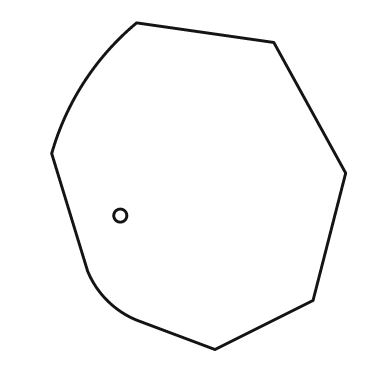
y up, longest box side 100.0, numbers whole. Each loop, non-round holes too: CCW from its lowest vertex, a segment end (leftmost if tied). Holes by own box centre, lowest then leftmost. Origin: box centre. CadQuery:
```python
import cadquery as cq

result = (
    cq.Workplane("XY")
    .moveTo(5.0, -50.0)
    .lineTo(35.0, -35.0)
    .lineTo(45.0, 4.0)
    .lineTo(23.0, 44.0)
    .lineTo(-19.0, 50.0)
    .threePointArc((-35.0, 32.0), (-45.0, 10.0))
    .lineTo(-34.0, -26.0)
    .threePointArc((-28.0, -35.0), (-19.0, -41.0))
    .close()
    .moveTo(-24.0, -9.0)
    .circle(2.0)
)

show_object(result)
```